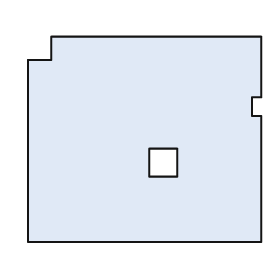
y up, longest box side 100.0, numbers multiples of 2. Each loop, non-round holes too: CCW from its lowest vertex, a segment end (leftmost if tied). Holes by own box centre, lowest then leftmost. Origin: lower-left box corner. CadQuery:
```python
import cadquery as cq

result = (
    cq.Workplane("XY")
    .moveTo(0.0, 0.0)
    .lineTo(100.0, 0.0)
    .lineTo(100.0, 54.0)
    .lineTo(96.0, 54.0)
    .lineTo(96.0, 62.0)
    .lineTo(100.0, 62.0)
    .lineTo(100.0, 88.0)
    .lineTo(10.0, 88.0)
    .lineTo(10.0, 78.0)
    .lineTo(0.0, 78.0)
    .close()
    .moveTo(52.0, 28.0)
    .lineTo(64.0, 28.0)
    .lineTo(64.0, 40.0)
    .lineTo(52.0, 40.0)
    .close()
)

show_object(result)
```